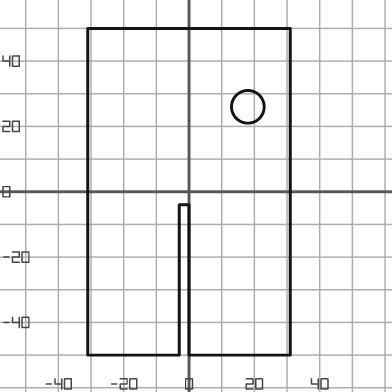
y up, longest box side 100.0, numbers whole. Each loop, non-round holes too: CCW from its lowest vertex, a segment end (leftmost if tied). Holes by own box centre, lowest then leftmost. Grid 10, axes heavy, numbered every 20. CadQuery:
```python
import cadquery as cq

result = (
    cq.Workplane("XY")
    .moveTo(-31.0, -50.0)
    .lineTo(-3.0, -50.0)
    .lineTo(-3.0, -4.0)
    .lineTo(0.0, -4.0)
    .lineTo(0.0, -50.0)
    .lineTo(31.0, -50.0)
    .lineTo(31.0, 50.0)
    .lineTo(-31.0, 50.0)
    .close()
    .moveTo(18.0, 26.0)
    .circle(5.0)
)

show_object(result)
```